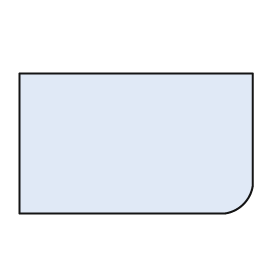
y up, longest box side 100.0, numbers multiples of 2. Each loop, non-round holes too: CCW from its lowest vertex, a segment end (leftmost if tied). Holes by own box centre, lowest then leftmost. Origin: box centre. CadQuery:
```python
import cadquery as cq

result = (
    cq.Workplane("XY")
    .moveTo(-50.0, -30.0)
    .lineTo(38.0, -30.0)
    .threePointArc((46.0, -26.0), (50.0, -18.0))
    .lineTo(50.0, 30.0)
    .lineTo(-50.0, 30.0)
    .close()
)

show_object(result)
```